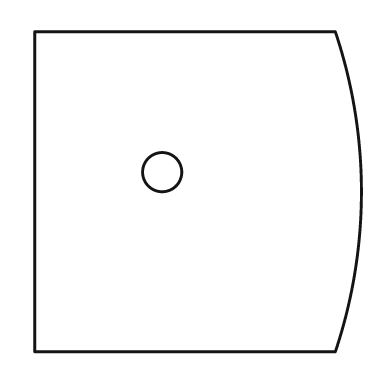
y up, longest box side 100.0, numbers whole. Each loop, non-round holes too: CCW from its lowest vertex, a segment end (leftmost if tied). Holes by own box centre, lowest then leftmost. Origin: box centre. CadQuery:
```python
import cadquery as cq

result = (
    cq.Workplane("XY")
    .moveTo(-50.0, -49.0)
    .lineTo(42.0, -49.0)
    .threePointArc((50.0, 0.0), (42.0, 49.0))
    .lineTo(-50.0, 49.0)
    .close()
    .moveTo(-11.0, 6.0)
    .circle(6.0)
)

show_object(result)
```